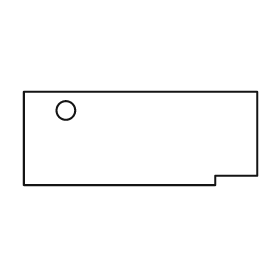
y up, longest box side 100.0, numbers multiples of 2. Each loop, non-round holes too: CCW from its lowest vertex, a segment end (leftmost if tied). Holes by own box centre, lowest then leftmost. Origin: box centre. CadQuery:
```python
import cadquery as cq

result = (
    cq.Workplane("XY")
    .moveTo(-50.0, -20.0)
    .lineTo(32.0, -20.0)
    .lineTo(32.0, -16.0)
    .lineTo(50.0, -16.0)
    .lineTo(50.0, 20.0)
    .lineTo(-50.0, 20.0)
    .close()
    .moveTo(-32.0, 12.0)
    .circle(4.0)
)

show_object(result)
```